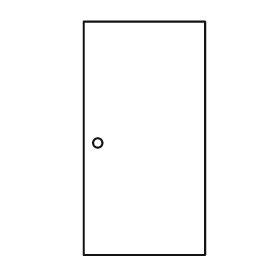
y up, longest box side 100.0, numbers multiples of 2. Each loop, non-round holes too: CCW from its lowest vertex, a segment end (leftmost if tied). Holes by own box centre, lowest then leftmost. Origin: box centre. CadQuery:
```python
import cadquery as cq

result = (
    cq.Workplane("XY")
    .moveTo(-26.0, -50.0)
    .lineTo(26.0, -50.0)
    .lineTo(26.0, 50.0)
    .lineTo(-26.0, 50.0)
    .close()
    .moveTo(-20.0, -2.0)
    .circle(2.0)
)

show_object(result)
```